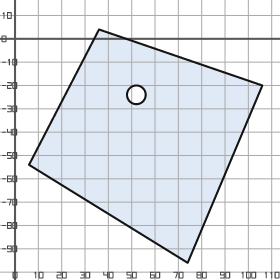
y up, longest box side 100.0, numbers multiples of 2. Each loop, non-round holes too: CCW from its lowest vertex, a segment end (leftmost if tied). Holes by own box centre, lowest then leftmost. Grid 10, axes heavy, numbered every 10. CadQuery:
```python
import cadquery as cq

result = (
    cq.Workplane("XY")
    .moveTo(74.0, -96.0)
    .lineTo(106.0, -20.0)
    .lineTo(36.0, 4.0)
    .lineTo(6.0, -54.0)
    .close()
    .moveTo(52.0, -24.0)
    .circle(4.0)
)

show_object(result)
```